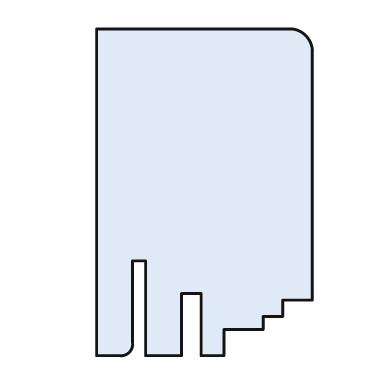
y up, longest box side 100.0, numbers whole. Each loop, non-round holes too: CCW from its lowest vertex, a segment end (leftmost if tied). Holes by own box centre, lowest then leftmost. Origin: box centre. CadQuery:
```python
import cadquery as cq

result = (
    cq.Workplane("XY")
    .moveTo(-33.0, -50.0)
    .lineTo(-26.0, -50.0)
    .threePointArc((-23.0, -49.0), (-22.0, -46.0))
    .lineTo(-22.0, -21.0)
    .lineTo(-18.0, -21.0)
    .lineTo(-18.0, -50.0)
    .lineTo(-7.0, -50.0)
    .lineTo(-7.0, -31.0)
    .lineTo(-1.0, -31.0)
    .lineTo(-1.0, -50.0)
    .lineTo(6.0, -50.0)
    .lineTo(6.0, -42.0)
    .lineTo(18.0, -42.0)
    .lineTo(18.0, -38.0)
    .lineTo(24.0, -38.0)
    .lineTo(24.0, -33.0)
    .lineTo(33.0, -33.0)
    .lineTo(33.0, 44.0)
    .threePointArc((31.0, 48.0), (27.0, 50.0))
    .lineTo(-33.0, 50.0)
    .close()
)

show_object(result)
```